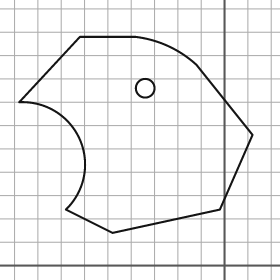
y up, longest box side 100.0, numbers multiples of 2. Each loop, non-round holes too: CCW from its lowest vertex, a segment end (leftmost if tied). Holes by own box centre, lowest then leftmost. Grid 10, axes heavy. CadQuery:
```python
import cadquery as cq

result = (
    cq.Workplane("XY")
    .moveTo(-48.0, 14.0)
    .lineTo(-2.0, 24.0)
    .lineTo(12.0, 56.0)
    .lineTo(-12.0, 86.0)
    .threePointArc((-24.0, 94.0), (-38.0, 98.0))
    .lineTo(-62.0, 98.0)
    .lineTo(-88.0, 70.0)
    .threePointArc((-62.0, 54.0), (-68.0, 24.0))
    .close()
    .moveTo(-34.0, 76.0)
    .circle(4.0)
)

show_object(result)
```